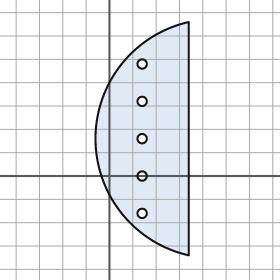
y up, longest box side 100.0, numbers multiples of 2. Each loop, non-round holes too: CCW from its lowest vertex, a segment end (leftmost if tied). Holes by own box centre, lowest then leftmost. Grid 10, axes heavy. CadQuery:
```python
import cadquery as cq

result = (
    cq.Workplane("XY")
    .moveTo(34.0, -34.0)
    .lineTo(34.0, 66.0)
    .threePointArc((-6.0, 16.0), (34.0, -34.0))
    .close()
    .moveTo(14.0, -16.0)
    .circle(2.0)
    .moveTo(14.0, 0.0)
    .circle(2.0)
    .moveTo(14.0, 16.0)
    .circle(2.0)
    .moveTo(14.0, 32.0)
    .circle(2.0)
    .moveTo(14.0, 48.0)
    .circle(2.0)
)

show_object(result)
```